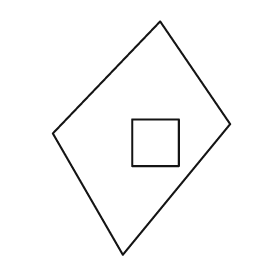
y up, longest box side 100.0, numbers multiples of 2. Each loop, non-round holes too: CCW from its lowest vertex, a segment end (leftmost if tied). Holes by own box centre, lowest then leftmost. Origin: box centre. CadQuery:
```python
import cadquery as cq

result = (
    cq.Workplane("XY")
    .moveTo(-8.0, -50.0)
    .lineTo(38.0, 6.0)
    .lineTo(8.0, 50.0)
    .lineTo(-38.0, 2.0)
    .close()
    .moveTo(-4.0, -12.0)
    .lineTo(16.0, -12.0)
    .lineTo(16.0, 8.0)
    .lineTo(-4.0, 8.0)
    .close()
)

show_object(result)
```